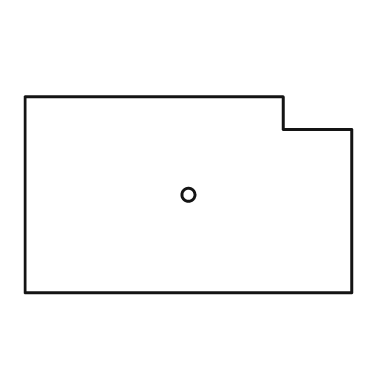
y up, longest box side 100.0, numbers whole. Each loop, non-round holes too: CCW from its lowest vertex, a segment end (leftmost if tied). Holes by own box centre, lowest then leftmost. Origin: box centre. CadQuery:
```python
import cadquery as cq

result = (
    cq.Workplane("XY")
    .moveTo(-50.0, -30.0)
    .lineTo(50.0, -30.0)
    .lineTo(50.0, 20.0)
    .lineTo(29.0, 20.0)
    .lineTo(29.0, 30.0)
    .lineTo(-50.0, 30.0)
    .close()
    .moveTo(0.0, 0.0)
    .circle(2.0)
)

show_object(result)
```